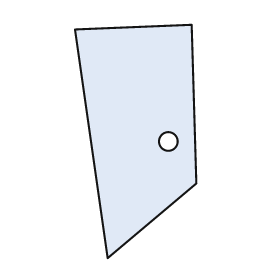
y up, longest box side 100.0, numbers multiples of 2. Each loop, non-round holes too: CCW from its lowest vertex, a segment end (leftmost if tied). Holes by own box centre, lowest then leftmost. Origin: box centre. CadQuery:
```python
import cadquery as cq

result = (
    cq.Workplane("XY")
    .moveTo(-12.0, -50.0)
    .lineTo(26.0, -18.0)
    .lineTo(24.0, 50.0)
    .lineTo(-26.0, 48.0)
    .close()
    .moveTo(14.0, 0.0)
    .circle(4.0)
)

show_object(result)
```